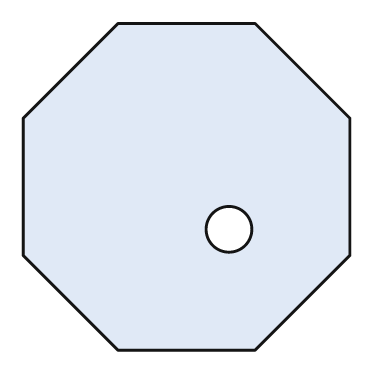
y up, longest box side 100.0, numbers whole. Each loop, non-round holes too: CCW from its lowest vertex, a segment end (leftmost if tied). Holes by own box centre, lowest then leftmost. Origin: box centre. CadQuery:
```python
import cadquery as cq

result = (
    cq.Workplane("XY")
    .moveTo(-21.0, -50.0)
    .lineTo(21.0, -50.0)
    .lineTo(50.0, -21.0)
    .lineTo(50.0, 21.0)
    .lineTo(21.0, 50.0)
    .lineTo(-21.0, 50.0)
    .lineTo(-50.0, 21.0)
    .lineTo(-50.0, -21.0)
    .close()
    .moveTo(13.0, -13.0)
    .circle(7.0)
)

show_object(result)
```